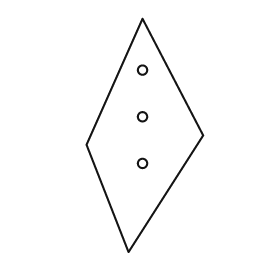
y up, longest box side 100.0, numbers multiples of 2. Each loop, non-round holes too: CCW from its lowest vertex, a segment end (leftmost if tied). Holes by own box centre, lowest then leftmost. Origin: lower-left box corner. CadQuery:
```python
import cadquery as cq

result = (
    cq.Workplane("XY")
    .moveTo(18.0, 0.0)
    .lineTo(50.0, 50.0)
    .lineTo(24.0, 100.0)
    .lineTo(0.0, 46.0)
    .close()
    .moveTo(24.0, 38.0)
    .circle(2.0)
    .moveTo(24.0, 58.0)
    .circle(2.0)
    .moveTo(24.0, 78.0)
    .circle(2.0)
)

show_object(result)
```